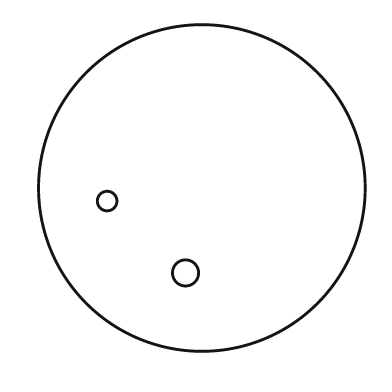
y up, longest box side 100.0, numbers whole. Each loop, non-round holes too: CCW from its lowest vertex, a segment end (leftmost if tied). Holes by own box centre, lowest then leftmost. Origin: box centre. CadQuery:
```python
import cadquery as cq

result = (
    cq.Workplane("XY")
    .moveTo(0.0, 0.0)
    .circle(50.0)
    .moveTo(-5.0, -26.0)
    .circle(4.0)
    .moveTo(-29.0, -4.0)
    .circle(3.0)
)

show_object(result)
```